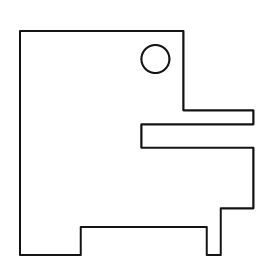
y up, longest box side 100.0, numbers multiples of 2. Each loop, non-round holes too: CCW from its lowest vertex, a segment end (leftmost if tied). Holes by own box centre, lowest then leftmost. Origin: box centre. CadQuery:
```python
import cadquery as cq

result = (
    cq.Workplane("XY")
    .moveTo(-50.0, -48.0)
    .lineTo(-24.0, -48.0)
    .lineTo(-24.0, -36.0)
    .lineTo(30.0, -36.0)
    .lineTo(30.0, -48.0)
    .lineTo(36.0, -48.0)
    .lineTo(36.0, -28.0)
    .lineTo(50.0, -28.0)
    .lineTo(50.0, -2.0)
    .lineTo(2.0, -2.0)
    .lineTo(2.0, 8.0)
    .lineTo(50.0, 8.0)
    .lineTo(50.0, 14.0)
    .lineTo(20.0, 14.0)
    .lineTo(20.0, 48.0)
    .lineTo(-50.0, 48.0)
    .close()
    .moveTo(8.0, 36.0)
    .circle(6.0)
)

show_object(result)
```